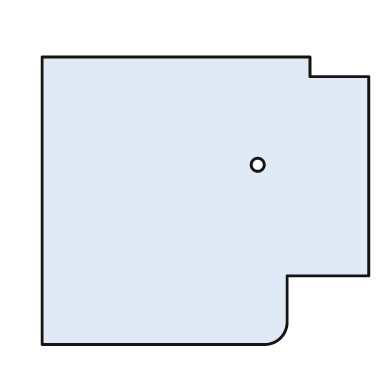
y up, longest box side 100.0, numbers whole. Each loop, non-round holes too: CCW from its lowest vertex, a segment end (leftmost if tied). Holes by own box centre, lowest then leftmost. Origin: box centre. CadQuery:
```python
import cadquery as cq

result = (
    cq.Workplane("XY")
    .moveTo(-50.0, -44.0)
    .lineTo(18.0, -44.0)
    .threePointArc((23.0, -42.0), (25.0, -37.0))
    .lineTo(25.0, -23.0)
    .lineTo(50.0, -23.0)
    .lineTo(50.0, 38.0)
    .lineTo(32.0, 38.0)
    .lineTo(32.0, 44.0)
    .lineTo(-50.0, 44.0)
    .close()
    .moveTo(16.0, 11.0)
    .circle(2.0)
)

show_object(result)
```